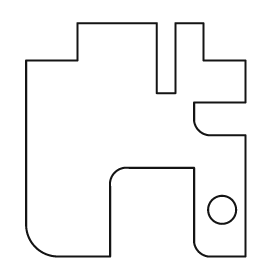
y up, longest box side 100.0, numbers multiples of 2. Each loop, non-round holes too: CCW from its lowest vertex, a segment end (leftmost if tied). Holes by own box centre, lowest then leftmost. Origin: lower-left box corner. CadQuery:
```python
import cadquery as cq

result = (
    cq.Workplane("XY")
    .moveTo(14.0, 0.0)
    .lineTo(36.0, 0.0)
    .lineTo(36.0, 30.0)
    .threePointArc((38.0, 36.0), (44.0, 38.0))
    .lineTo(72.0, 38.0)
    .lineTo(72.0, 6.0)
    .threePointArc((74.0, 2.0), (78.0, 0.0))
    .lineTo(94.0, 0.0)
    .lineTo(94.0, 52.0)
    .lineTo(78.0, 52.0)
    .threePointArc((74.0, 54.0), (72.0, 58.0))
    .lineTo(72.0, 66.0)
    .lineTo(94.0, 66.0)
    .lineTo(94.0, 84.0)
    .lineTo(76.0, 84.0)
    .lineTo(76.0, 100.0)
    .lineTo(64.0, 100.0)
    .lineTo(64.0, 70.0)
    .lineTo(56.0, 70.0)
    .lineTo(56.0, 100.0)
    .lineTo(22.0, 100.0)
    .lineTo(22.0, 84.0)
    .lineTo(0.0, 84.0)
    .lineTo(0.0, 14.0)
    .threePointArc((4.0, 4.0), (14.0, 0.0))
    .close()
    .moveTo(84.0, 20.0)
    .circle(6.0)
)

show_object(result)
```